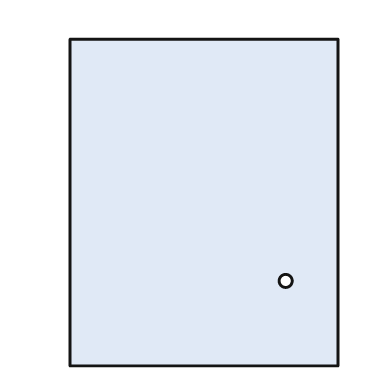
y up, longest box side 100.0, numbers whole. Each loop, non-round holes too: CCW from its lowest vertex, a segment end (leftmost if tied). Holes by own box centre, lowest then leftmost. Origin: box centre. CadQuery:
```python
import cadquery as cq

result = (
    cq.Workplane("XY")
    .moveTo(-41.0, -50.0)
    .lineTo(41.0, -50.0)
    .lineTo(41.0, 50.0)
    .lineTo(-41.0, 50.0)
    .close()
    .moveTo(25.0, -24.0)
    .circle(2.0)
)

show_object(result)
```